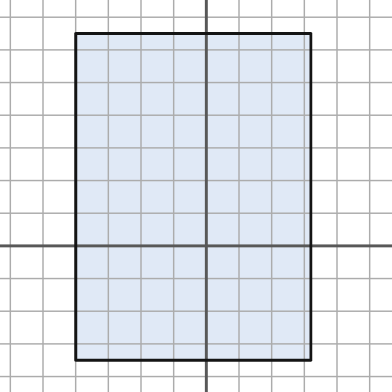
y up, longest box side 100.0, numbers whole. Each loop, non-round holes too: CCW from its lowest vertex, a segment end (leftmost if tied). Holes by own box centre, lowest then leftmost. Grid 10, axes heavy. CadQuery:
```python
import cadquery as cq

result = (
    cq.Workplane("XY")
    .moveTo(-40.0, -35.0)
    .lineTo(32.0, -35.0)
    .lineTo(32.0, 65.0)
    .lineTo(-40.0, 65.0)
    .close()
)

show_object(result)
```